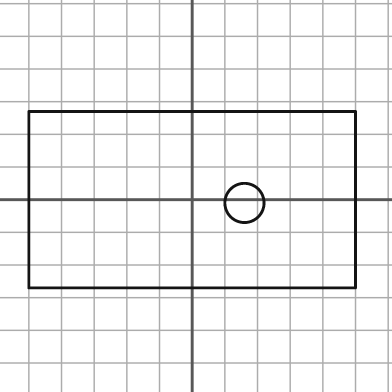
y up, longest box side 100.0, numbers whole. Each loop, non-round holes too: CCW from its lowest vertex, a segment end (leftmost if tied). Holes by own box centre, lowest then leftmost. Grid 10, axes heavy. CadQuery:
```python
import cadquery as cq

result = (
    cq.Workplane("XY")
    .moveTo(-50.0, -27.0)
    .lineTo(50.0, -27.0)
    .lineTo(50.0, 27.0)
    .lineTo(-50.0, 27.0)
    .close()
    .moveTo(16.0, -1.0)
    .circle(6.0)
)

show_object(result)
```